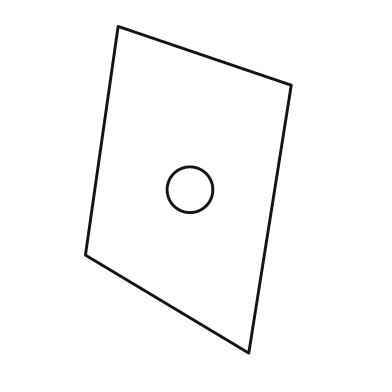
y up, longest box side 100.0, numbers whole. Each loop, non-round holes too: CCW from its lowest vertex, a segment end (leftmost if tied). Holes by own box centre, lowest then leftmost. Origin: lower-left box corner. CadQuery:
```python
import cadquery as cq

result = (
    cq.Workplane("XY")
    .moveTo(50.0, 0.0)
    .lineTo(63.0, 82.0)
    .lineTo(10.0, 100.0)
    .lineTo(0.0, 30.0)
    .close()
    .moveTo(32.0, 50.0)
    .circle(7.0)
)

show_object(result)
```